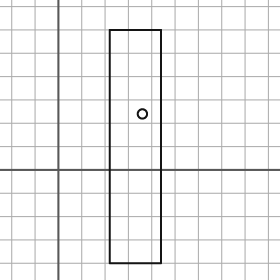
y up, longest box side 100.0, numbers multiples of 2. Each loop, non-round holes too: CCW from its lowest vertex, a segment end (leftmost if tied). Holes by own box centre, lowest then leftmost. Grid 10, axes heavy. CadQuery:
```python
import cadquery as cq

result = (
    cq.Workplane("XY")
    .moveTo(22.0, -40.0)
    .lineTo(44.0, -40.0)
    .lineTo(44.0, 60.0)
    .lineTo(22.0, 60.0)
    .close()
    .moveTo(36.0, 24.0)
    .circle(2.0)
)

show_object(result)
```